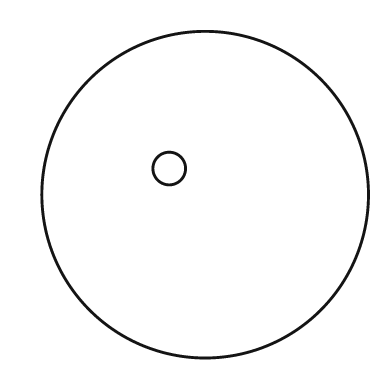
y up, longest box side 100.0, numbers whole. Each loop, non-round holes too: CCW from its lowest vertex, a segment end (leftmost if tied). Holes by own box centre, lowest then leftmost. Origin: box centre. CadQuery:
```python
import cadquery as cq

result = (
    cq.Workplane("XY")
    .moveTo(0.0, 0.0)
    .circle(50.0)
    .moveTo(-11.0, 8.0)
    .circle(5.0)
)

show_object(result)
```